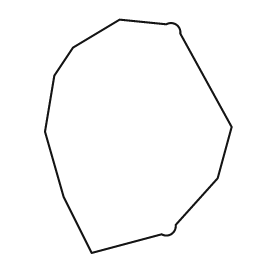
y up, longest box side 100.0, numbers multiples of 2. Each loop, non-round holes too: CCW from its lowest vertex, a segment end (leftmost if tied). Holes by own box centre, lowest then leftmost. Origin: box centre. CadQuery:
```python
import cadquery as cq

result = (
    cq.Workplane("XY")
    .moveTo(-20.0, -50.0)
    .lineTo(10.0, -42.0)
    .threePointArc((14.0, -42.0), (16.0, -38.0))
    .lineTo(34.0, -18.0)
    .lineTo(40.0, 4.0)
    .lineTo(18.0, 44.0)
    .threePointArc((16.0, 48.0), (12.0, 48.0))
    .lineTo(-8.0, 50.0)
    .lineTo(-28.0, 38.0)
    .lineTo(-36.0, 26.0)
    .lineTo(-40.0, 2.0)
    .lineTo(-32.0, -26.0)
    .close()
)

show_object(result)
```